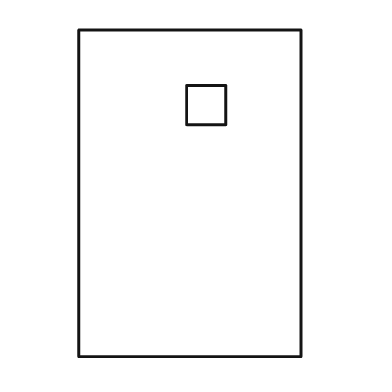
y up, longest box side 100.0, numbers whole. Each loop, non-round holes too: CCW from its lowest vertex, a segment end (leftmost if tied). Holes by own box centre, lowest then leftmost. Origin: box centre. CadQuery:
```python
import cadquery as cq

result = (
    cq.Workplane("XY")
    .moveTo(-34.0, -50.0)
    .lineTo(34.0, -50.0)
    .lineTo(34.0, 50.0)
    .lineTo(-34.0, 50.0)
    .close()
    .moveTo(-1.0, 21.0)
    .lineTo(11.0, 21.0)
    .lineTo(11.0, 33.0)
    .lineTo(-1.0, 33.0)
    .close()
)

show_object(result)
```